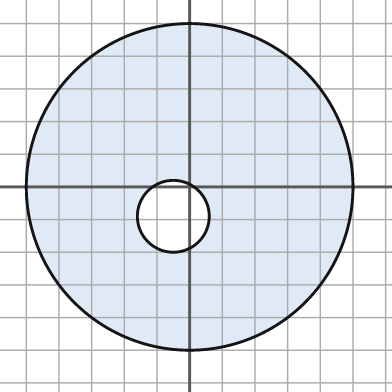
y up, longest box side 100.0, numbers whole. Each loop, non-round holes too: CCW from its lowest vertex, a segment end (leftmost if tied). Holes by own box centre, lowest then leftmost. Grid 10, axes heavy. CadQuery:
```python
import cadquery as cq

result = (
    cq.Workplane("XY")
    .moveTo(0.0, 0.0)
    .circle(50.0)
    .moveTo(-5.0, -9.0)
    .circle(11.0)
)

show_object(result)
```